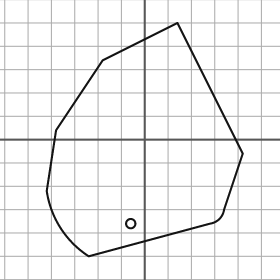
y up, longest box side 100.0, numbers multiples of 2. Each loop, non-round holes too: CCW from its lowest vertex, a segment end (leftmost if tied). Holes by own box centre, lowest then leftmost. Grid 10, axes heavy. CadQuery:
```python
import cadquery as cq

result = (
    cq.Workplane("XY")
    .moveTo(-24.0, -50.0)
    .lineTo(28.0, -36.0)
    .threePointArc((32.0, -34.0), (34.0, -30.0))
    .lineTo(42.0, -6.0)
    .lineTo(14.0, 50.0)
    .lineTo(-18.0, 34.0)
    .lineTo(-38.0, 4.0)
    .lineTo(-42.0, -22.0)
    .threePointArc((-36.0, -38.0), (-24.0, -50.0))
    .close()
    .moveTo(-6.0, -36.0)
    .circle(2.0)
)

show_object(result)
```